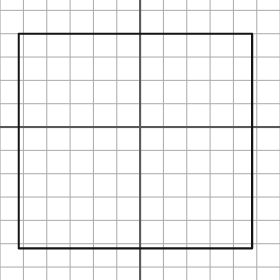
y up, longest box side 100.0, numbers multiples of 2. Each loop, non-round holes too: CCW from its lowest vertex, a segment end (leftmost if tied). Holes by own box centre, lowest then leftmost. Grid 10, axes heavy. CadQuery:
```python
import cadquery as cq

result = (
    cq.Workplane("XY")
    .moveTo(-52.0, -52.0)
    .lineTo(48.0, -52.0)
    .lineTo(48.0, 40.0)
    .lineTo(-52.0, 40.0)
    .close()
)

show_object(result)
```